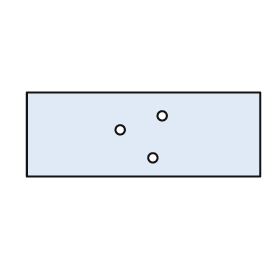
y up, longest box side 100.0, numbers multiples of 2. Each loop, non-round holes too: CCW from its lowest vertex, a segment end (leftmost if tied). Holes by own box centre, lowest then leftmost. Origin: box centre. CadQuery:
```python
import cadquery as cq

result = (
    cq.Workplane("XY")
    .moveTo(-50.0, -18.0)
    .lineTo(50.0, -18.0)
    .lineTo(50.0, 18.0)
    .lineTo(-50.0, 18.0)
    .close()
    .moveTo(4.0, -10.0)
    .circle(2.0)
    .moveTo(-10.0, 2.0)
    .circle(2.0)
    .moveTo(8.0, 8.0)
    .circle(2.0)
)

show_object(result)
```